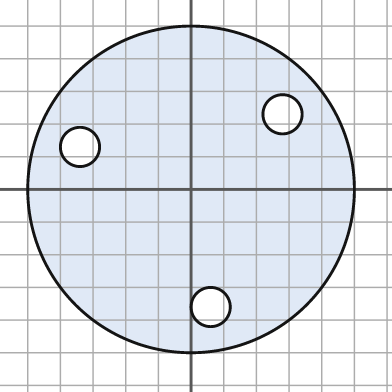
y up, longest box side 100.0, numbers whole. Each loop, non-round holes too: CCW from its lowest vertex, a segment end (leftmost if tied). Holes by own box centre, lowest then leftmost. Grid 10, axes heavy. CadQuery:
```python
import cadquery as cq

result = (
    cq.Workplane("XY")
    .moveTo(0.0, 0.0)
    .circle(50.0)
    .moveTo(6.0, -36.0)
    .circle(6.0)
    .moveTo(-34.0, 13.0)
    .circle(6.0)
    .moveTo(28.0, 23.0)
    .circle(6.0)
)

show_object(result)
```